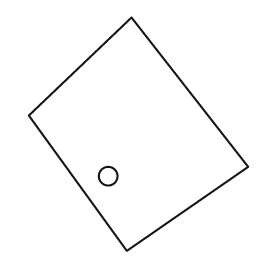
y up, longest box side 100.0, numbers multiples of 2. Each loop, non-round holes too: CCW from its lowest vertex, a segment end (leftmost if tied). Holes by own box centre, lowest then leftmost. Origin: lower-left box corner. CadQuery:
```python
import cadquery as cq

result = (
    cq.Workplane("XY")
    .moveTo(42.0, 0.0)
    .lineTo(94.0, 36.0)
    .lineTo(44.0, 100.0)
    .lineTo(0.0, 58.0)
    .close()
    .moveTo(34.0, 32.0)
    .circle(4.0)
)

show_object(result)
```